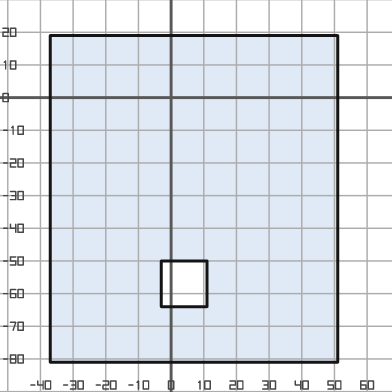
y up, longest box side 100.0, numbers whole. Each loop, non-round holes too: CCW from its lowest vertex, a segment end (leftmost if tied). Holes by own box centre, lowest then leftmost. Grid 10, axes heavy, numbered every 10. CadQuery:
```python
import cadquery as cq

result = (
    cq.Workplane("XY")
    .moveTo(-37.0, -81.0)
    .lineTo(51.0, -81.0)
    .lineTo(51.0, 19.0)
    .lineTo(-37.0, 19.0)
    .close()
    .moveTo(-3.0, -64.0)
    .lineTo(11.0, -64.0)
    .lineTo(11.0, -50.0)
    .lineTo(-3.0, -50.0)
    .close()
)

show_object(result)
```